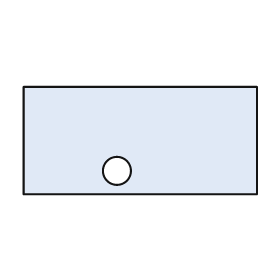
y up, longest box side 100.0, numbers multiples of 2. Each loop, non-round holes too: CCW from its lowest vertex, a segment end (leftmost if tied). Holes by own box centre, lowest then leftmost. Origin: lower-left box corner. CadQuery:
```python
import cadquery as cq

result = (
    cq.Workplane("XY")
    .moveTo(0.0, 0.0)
    .lineTo(100.0, 0.0)
    .lineTo(100.0, 46.0)
    .lineTo(0.0, 46.0)
    .close()
    .moveTo(40.0, 10.0)
    .circle(6.0)
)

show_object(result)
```